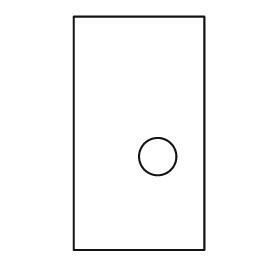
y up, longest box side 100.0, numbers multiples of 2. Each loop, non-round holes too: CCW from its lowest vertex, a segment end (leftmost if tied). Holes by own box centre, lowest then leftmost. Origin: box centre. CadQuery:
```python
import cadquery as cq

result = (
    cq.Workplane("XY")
    .moveTo(-28.0, -50.0)
    .lineTo(28.0, -50.0)
    .lineTo(28.0, 50.0)
    .lineTo(-28.0, 50.0)
    .close()
    .moveTo(8.0, -10.0)
    .circle(8.0)
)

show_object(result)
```